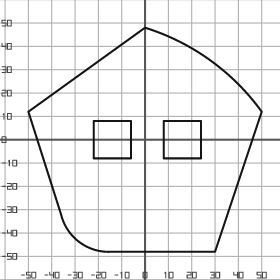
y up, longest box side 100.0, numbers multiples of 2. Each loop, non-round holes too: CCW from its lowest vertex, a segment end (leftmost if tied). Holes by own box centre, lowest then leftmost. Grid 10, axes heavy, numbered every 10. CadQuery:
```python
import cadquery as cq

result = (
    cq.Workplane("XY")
    .moveTo(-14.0, -48.0)
    .lineTo(30.0, -48.0)
    .lineTo(50.0, 12.0)
    .threePointArc((28.0, 34.0), (0.0, 48.0))
    .lineTo(-50.0, 12.0)
    .lineTo(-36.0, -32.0)
    .threePointArc((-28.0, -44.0), (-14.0, -48.0))
    .close()
    .moveTo(-22.0, -8.0)
    .lineTo(-6.0, -8.0)
    .lineTo(-6.0, 8.0)
    .lineTo(-22.0, 8.0)
    .close()
    .moveTo(8.0, -8.0)
    .lineTo(24.0, -8.0)
    .lineTo(24.0, 8.0)
    .lineTo(8.0, 8.0)
    .close()
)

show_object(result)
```